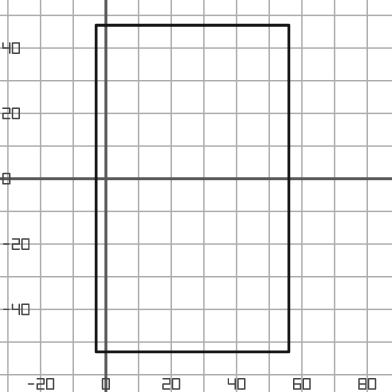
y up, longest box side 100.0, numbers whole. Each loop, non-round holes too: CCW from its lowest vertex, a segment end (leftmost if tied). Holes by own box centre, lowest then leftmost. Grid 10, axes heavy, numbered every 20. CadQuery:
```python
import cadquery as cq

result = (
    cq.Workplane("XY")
    .moveTo(-3.0, -53.0)
    .lineTo(56.0, -53.0)
    .lineTo(56.0, 47.0)
    .lineTo(-3.0, 47.0)
    .close()
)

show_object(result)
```